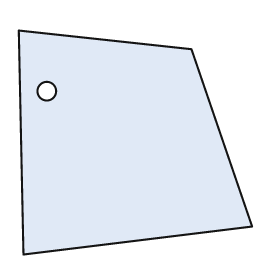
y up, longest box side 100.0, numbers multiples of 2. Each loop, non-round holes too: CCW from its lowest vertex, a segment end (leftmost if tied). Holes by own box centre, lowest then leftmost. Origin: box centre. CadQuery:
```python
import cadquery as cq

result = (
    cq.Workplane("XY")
    .moveTo(-48.0, -48.0)
    .lineTo(50.0, -36.0)
    .lineTo(24.0, 40.0)
    .lineTo(-50.0, 48.0)
    .close()
    .moveTo(-38.0, 22.0)
    .circle(4.0)
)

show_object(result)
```